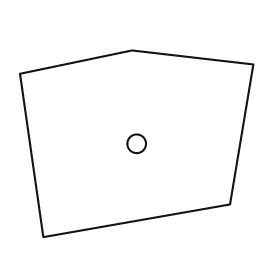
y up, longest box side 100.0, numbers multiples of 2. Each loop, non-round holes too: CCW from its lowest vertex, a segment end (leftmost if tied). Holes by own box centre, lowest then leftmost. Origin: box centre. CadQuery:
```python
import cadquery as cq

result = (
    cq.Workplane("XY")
    .moveTo(-40.0, -40.0)
    .lineTo(40.0, -26.0)
    .lineTo(50.0, 34.0)
    .lineTo(-2.0, 40.0)
    .lineTo(-50.0, 30.0)
    .close()
    .moveTo(0.0, 0.0)
    .circle(4.0)
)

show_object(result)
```